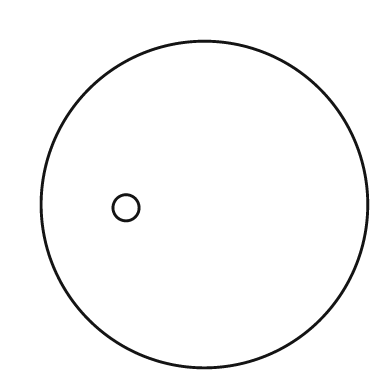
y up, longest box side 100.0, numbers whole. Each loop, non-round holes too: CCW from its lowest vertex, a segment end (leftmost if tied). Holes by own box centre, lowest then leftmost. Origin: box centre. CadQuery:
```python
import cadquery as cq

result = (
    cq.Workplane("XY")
    .moveTo(0.0, 0.0)
    .circle(50.0)
    .moveTo(-24.0, -1.0)
    .circle(4.0)
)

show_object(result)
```